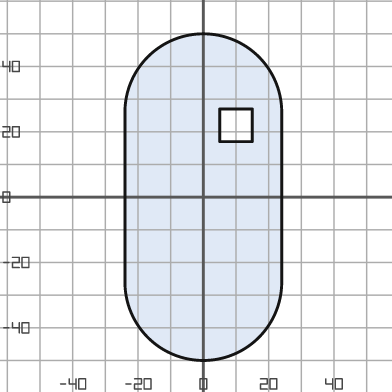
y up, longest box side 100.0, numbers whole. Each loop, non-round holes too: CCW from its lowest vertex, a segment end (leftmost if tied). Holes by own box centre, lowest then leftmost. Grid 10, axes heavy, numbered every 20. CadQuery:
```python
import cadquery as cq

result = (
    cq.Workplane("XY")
    .moveTo(-24.0, -26.0)
    .threePointArc((0.0, -50.0), (24.0, -26.0))
    .lineTo(24.0, 26.0)
    .threePointArc((0.0, 50.0), (-24.0, 26.0))
    .close()
    .moveTo(5.0, 17.0)
    .lineTo(15.0, 17.0)
    .lineTo(15.0, 27.0)
    .lineTo(5.0, 27.0)
    .close()
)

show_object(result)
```